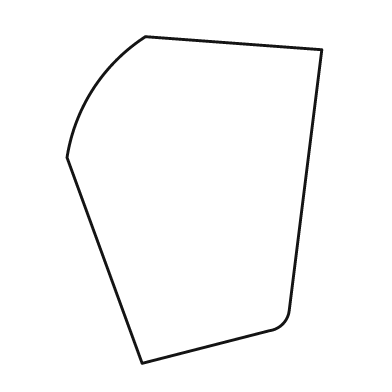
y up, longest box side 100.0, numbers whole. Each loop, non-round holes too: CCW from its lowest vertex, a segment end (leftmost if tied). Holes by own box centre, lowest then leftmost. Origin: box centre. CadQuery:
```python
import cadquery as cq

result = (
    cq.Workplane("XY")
    .moveTo(-16.0, -50.0)
    .lineTo(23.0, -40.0)
    .threePointArc((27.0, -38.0), (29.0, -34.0))
    .lineTo(39.0, 46.0)
    .lineTo(-15.0, 50.0)
    .threePointArc((-31.0, 34.0), (-39.0, 13.0))
    .close()
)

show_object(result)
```